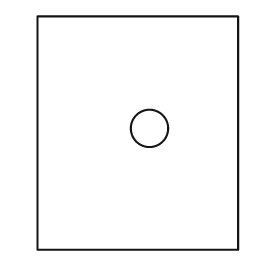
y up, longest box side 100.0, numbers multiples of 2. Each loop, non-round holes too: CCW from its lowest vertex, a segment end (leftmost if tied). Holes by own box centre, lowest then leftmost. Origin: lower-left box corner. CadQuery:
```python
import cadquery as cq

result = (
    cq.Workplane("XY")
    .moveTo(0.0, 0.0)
    .lineTo(86.0, 0.0)
    .lineTo(86.0, 100.0)
    .lineTo(0.0, 100.0)
    .close()
    .moveTo(48.0, 52.0)
    .circle(8.0)
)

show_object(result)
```